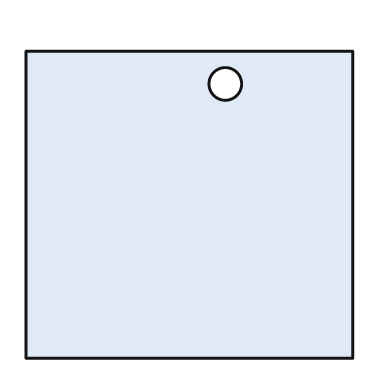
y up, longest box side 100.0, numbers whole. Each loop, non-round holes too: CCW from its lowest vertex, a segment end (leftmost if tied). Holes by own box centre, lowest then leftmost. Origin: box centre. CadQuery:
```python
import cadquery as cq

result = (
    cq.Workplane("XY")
    .moveTo(-50.0, -47.0)
    .lineTo(50.0, -47.0)
    .lineTo(50.0, 47.0)
    .lineTo(-50.0, 47.0)
    .close()
    .moveTo(11.0, 37.0)
    .circle(5.0)
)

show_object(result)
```